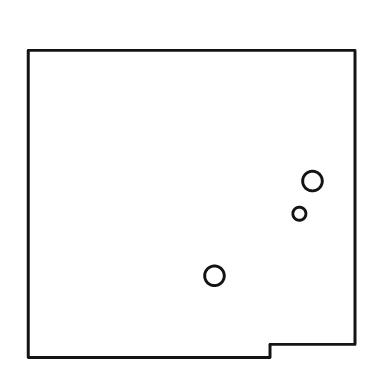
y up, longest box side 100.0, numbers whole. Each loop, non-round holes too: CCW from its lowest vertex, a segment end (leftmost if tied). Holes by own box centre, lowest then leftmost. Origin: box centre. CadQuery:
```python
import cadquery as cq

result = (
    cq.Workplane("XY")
    .moveTo(-50.0, -47.0)
    .lineTo(24.0, -47.0)
    .lineTo(24.0, -43.0)
    .lineTo(50.0, -43.0)
    .lineTo(50.0, 47.0)
    .lineTo(-50.0, 47.0)
    .close()
    .moveTo(7.0, -22.0)
    .circle(3.0)
    .moveTo(33.0, -3.0)
    .circle(2.0)
    .moveTo(37.0, 7.0)
    .circle(3.0)
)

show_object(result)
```